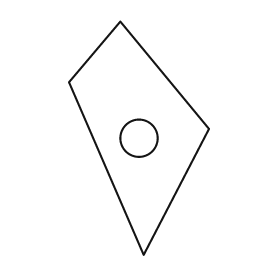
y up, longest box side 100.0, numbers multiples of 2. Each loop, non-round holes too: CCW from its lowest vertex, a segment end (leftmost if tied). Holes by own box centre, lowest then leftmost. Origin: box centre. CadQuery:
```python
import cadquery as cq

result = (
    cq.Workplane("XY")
    .moveTo(2.0, -50.0)
    .lineTo(30.0, 4.0)
    .lineTo(-8.0, 50.0)
    .lineTo(-30.0, 24.0)
    .close()
    .moveTo(0.0, 0.0)
    .circle(8.0)
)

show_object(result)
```